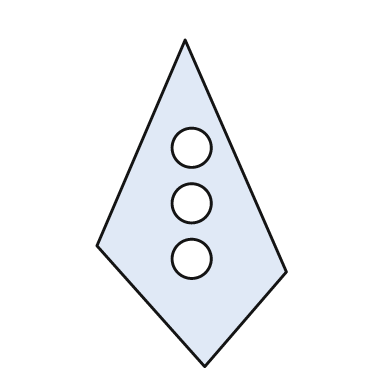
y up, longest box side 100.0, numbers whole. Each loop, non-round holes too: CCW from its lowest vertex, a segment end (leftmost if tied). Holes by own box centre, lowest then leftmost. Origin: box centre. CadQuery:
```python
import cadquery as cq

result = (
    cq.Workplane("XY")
    .moveTo(4.0, -50.0)
    .lineTo(29.0, -21.0)
    .lineTo(-2.0, 50.0)
    .lineTo(-29.0, -13.0)
    .close()
    .moveTo(0.0, -17.0)
    .circle(6.0)
    .moveTo(0.0, 0.0)
    .circle(6.0)
    .moveTo(0.0, 17.0)
    .circle(6.0)
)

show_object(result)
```